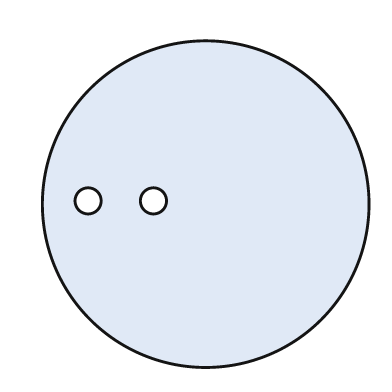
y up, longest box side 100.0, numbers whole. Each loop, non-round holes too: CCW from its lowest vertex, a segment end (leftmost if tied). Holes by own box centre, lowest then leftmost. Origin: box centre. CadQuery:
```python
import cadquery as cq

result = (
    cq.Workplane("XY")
    .moveTo(0.0, 0.0)
    .circle(50.0)
    .moveTo(-36.0, 1.0)
    .circle(4.0)
    .moveTo(-16.0, 1.0)
    .circle(4.0)
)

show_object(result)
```